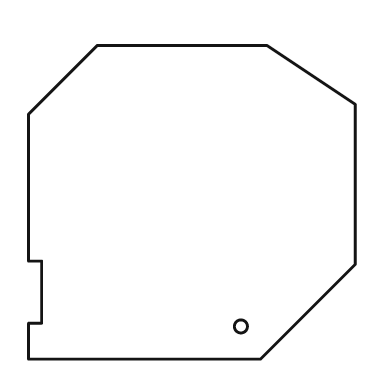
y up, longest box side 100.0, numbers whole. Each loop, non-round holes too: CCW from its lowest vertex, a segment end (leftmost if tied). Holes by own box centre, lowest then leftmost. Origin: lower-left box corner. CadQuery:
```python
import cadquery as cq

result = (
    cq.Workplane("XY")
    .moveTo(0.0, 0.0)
    .lineTo(71.0, 0.0)
    .lineTo(100.0, 29.0)
    .lineTo(100.0, 78.0)
    .lineTo(73.0, 96.0)
    .lineTo(21.0, 96.0)
    .lineTo(0.0, 75.0)
    .lineTo(0.0, 30.0)
    .lineTo(4.0, 30.0)
    .lineTo(4.0, 11.0)
    .lineTo(0.0, 11.0)
    .close()
    .moveTo(65.0, 10.0)
    .circle(2.0)
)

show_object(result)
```